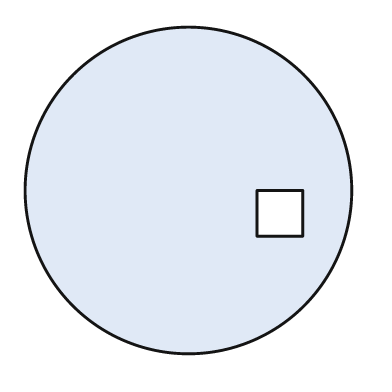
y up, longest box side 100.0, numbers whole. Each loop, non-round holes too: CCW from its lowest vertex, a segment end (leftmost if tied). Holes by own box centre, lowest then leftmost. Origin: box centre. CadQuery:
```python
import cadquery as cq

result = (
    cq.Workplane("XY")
    .moveTo(0.0, 0.0)
    .circle(50.0)
    .moveTo(21.0, -14.0)
    .lineTo(35.0, -14.0)
    .lineTo(35.0, 0.0)
    .lineTo(21.0, 0.0)
    .close()
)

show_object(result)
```